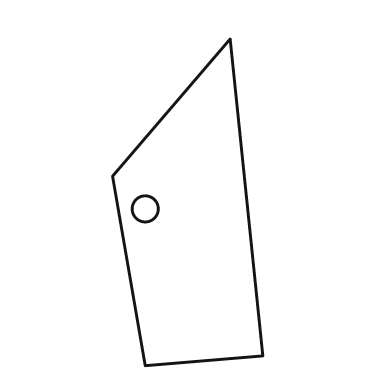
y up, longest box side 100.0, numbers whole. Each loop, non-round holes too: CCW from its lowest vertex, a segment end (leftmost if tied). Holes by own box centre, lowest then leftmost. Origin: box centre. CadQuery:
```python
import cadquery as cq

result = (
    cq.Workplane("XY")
    .moveTo(-13.0, -50.0)
    .lineTo(23.0, -47.0)
    .lineTo(13.0, 50.0)
    .lineTo(-23.0, 8.0)
    .close()
    .moveTo(-13.0, -2.0)
    .circle(4.0)
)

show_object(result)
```